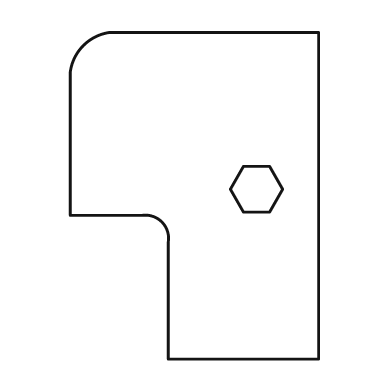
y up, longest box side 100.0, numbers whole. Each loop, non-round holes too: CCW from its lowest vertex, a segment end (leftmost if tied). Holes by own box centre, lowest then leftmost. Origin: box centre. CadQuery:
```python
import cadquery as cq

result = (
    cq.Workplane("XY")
    .moveTo(-8.0, -50.0)
    .lineTo(38.0, -50.0)
    .lineTo(38.0, 50.0)
    .lineTo(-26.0, 50.0)
    .threePointArc((-34.0, 46.0), (-38.0, 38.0))
    .lineTo(-38.0, -6.0)
    .lineTo(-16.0, -6.0)
    .threePointArc((-10.0, -8.0), (-8.0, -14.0))
    .close()
    .moveTo(15.0, -5.0)
    .lineTo(23.0, -5.0)
    .lineTo(27.0, 2.0)
    .lineTo(23.0, 9.0)
    .lineTo(15.0, 9.0)
    .lineTo(11.0, 2.0)
    .close()
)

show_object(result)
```